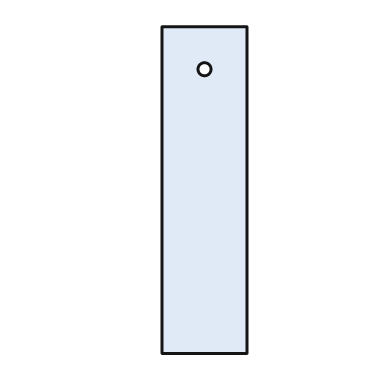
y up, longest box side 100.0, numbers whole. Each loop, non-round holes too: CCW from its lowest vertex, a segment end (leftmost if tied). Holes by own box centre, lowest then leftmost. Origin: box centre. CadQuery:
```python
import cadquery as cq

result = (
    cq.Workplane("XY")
    .moveTo(-13.0, -50.0)
    .lineTo(13.0, -50.0)
    .lineTo(13.0, 50.0)
    .lineTo(-13.0, 50.0)
    .close()
    .moveTo(0.0, 37.0)
    .circle(2.0)
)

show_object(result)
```